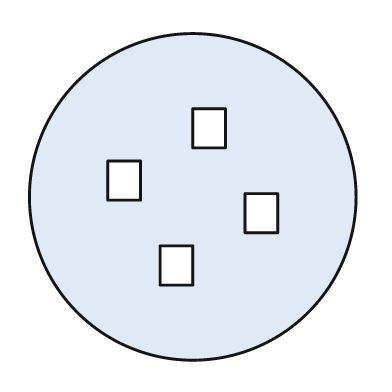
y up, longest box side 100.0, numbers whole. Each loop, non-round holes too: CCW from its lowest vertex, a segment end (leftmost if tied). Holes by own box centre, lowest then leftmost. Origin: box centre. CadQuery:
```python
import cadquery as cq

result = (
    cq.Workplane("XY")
    .moveTo(0.0, 0.0)
    .circle(50.0)
    .moveTo(-10.0, -27.0)
    .lineTo(0.0, -27.0)
    .lineTo(0.0, -15.0)
    .lineTo(-10.0, -15.0)
    .close()
    .moveTo(16.0, -11.0)
    .lineTo(26.0, -11.0)
    .lineTo(26.0, 1.0)
    .lineTo(16.0, 1.0)
    .close()
    .moveTo(-26.0, -1.0)
    .lineTo(-16.0, -1.0)
    .lineTo(-16.0, 11.0)
    .lineTo(-26.0, 11.0)
    .close()
    .moveTo(0.0, 15.0)
    .lineTo(10.0, 15.0)
    .lineTo(10.0, 27.0)
    .lineTo(0.0, 27.0)
    .close()
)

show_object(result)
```